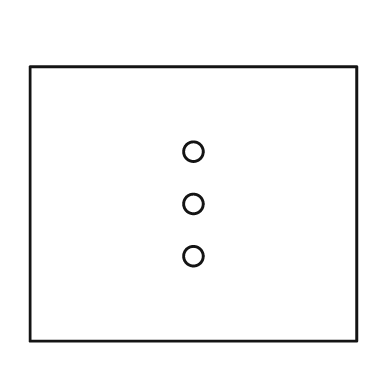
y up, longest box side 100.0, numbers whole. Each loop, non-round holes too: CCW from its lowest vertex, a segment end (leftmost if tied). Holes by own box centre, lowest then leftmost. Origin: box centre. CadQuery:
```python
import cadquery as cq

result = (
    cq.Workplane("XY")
    .moveTo(-50.0, -42.0)
    .lineTo(50.0, -42.0)
    .lineTo(50.0, 42.0)
    .lineTo(-50.0, 42.0)
    .close()
    .moveTo(0.0, -16.0)
    .circle(3.0)
    .moveTo(0.0, 0.0)
    .circle(3.0)
    .moveTo(0.0, 16.0)
    .circle(3.0)
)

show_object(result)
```